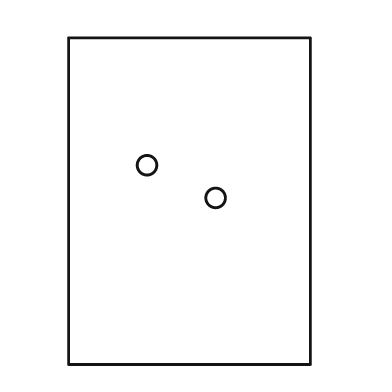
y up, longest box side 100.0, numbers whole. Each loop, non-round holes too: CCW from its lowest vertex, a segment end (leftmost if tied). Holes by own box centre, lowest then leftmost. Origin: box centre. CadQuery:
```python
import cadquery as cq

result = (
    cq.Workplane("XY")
    .moveTo(-37.0, -50.0)
    .lineTo(37.0, -50.0)
    .lineTo(37.0, 50.0)
    .lineTo(-37.0, 50.0)
    .close()
    .moveTo(8.0, 1.0)
    .circle(3.0)
    .moveTo(-13.0, 11.0)
    .circle(3.0)
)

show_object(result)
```